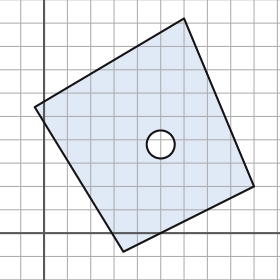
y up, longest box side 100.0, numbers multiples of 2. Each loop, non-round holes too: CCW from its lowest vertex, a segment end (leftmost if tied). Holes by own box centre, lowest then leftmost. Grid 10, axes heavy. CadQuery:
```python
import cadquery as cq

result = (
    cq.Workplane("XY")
    .moveTo(34.0, -8.0)
    .lineTo(90.0, 20.0)
    .lineTo(60.0, 92.0)
    .lineTo(-4.0, 54.0)
    .close()
    .moveTo(50.0, 38.0)
    .circle(6.0)
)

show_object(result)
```